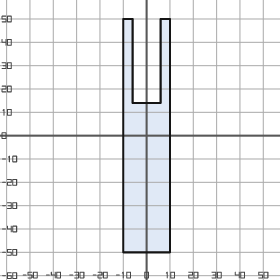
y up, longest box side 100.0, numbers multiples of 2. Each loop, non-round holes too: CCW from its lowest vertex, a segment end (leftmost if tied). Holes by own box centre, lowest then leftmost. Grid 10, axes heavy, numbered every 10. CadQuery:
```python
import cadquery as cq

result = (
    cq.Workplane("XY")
    .moveTo(-10.0, -50.0)
    .lineTo(10.0, -50.0)
    .lineTo(10.0, 50.0)
    .lineTo(6.0, 50.0)
    .lineTo(6.0, 14.0)
    .lineTo(-6.0, 14.0)
    .lineTo(-6.0, 50.0)
    .lineTo(-10.0, 50.0)
    .close()
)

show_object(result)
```